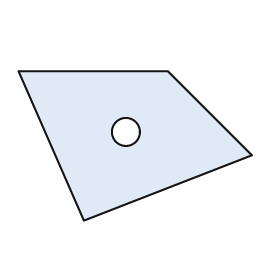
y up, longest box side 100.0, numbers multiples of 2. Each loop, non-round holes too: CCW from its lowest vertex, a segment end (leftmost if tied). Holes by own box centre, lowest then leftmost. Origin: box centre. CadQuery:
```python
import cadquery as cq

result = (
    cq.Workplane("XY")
    .moveTo(-22.0, -32.0)
    .lineTo(50.0, -4.0)
    .lineTo(14.0, 32.0)
    .lineTo(-50.0, 32.0)
    .close()
    .moveTo(-4.0, 6.0)
    .circle(6.0)
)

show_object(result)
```